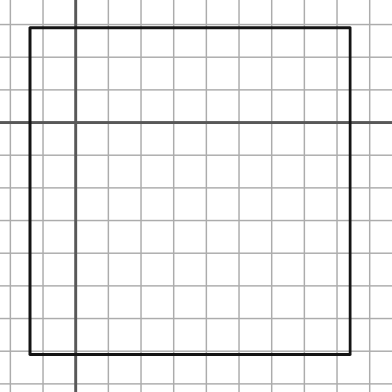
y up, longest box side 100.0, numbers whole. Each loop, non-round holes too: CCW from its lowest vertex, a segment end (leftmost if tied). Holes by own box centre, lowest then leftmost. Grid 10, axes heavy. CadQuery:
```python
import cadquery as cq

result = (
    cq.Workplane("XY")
    .moveTo(-14.0, -71.0)
    .lineTo(84.0, -71.0)
    .lineTo(84.0, 29.0)
    .lineTo(-14.0, 29.0)
    .close()
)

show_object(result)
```